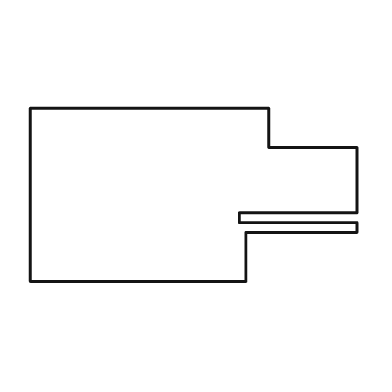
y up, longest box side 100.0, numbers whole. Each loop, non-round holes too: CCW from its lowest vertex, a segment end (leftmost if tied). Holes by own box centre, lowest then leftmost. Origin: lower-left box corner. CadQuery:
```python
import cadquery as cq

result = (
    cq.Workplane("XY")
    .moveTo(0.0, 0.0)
    .lineTo(66.0, 0.0)
    .lineTo(66.0, 15.0)
    .lineTo(100.0, 15.0)
    .lineTo(100.0, 18.0)
    .lineTo(64.0, 18.0)
    .lineTo(64.0, 21.0)
    .lineTo(100.0, 21.0)
    .lineTo(100.0, 41.0)
    .lineTo(73.0, 41.0)
    .lineTo(73.0, 53.0)
    .lineTo(0.0, 53.0)
    .close()
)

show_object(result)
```